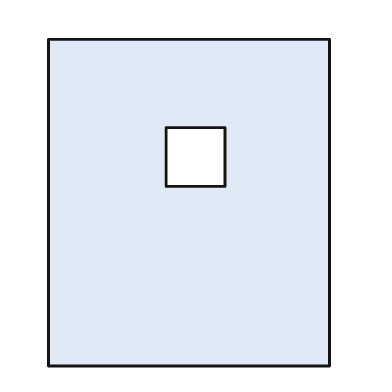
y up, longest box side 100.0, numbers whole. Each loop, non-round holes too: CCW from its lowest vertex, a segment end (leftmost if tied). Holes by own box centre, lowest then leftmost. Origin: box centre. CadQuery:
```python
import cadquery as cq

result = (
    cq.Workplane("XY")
    .moveTo(-43.0, -50.0)
    .lineTo(43.0, -50.0)
    .lineTo(43.0, 50.0)
    .lineTo(-43.0, 50.0)
    .close()
    .moveTo(-7.0, 5.0)
    .lineTo(11.0, 5.0)
    .lineTo(11.0, 23.0)
    .lineTo(-7.0, 23.0)
    .close()
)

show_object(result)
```